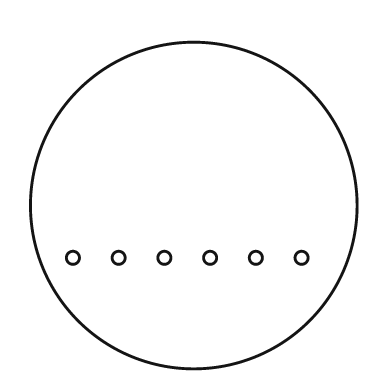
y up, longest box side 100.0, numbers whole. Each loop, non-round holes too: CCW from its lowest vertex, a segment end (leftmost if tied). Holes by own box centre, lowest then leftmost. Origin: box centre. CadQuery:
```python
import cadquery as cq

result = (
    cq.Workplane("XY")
    .moveTo(0.0, 0.0)
    .circle(50.0)
    .moveTo(-37.0, -16.0)
    .circle(2.0)
    .moveTo(-23.0, -16.0)
    .circle(2.0)
    .moveTo(-9.0, -16.0)
    .circle(2.0)
    .moveTo(5.0, -16.0)
    .circle(2.0)
    .moveTo(19.0, -16.0)
    .circle(2.0)
    .moveTo(33.0, -16.0)
    .circle(2.0)
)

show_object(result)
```